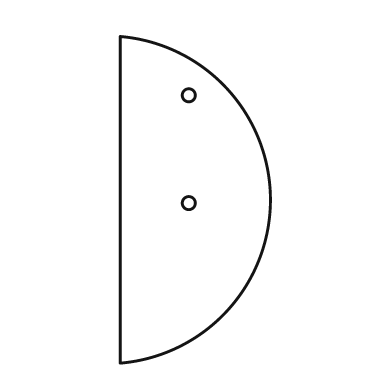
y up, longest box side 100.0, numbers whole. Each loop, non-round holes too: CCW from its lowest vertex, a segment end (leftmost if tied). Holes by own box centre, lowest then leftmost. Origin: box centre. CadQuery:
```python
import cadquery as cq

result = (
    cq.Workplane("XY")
    .moveTo(-23.0, -50.0)
    .threePointArc((23.0, 0.0), (-23.0, 50.0))
    .close()
    .moveTo(-2.0, -1.0)
    .circle(2.0)
    .moveTo(-2.0, 32.0)
    .circle(2.0)
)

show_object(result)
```